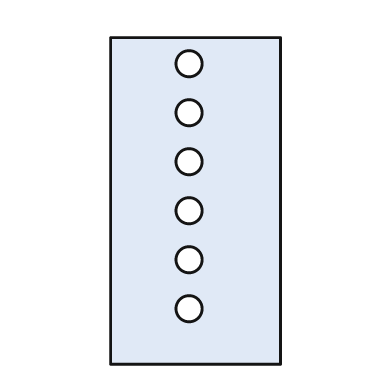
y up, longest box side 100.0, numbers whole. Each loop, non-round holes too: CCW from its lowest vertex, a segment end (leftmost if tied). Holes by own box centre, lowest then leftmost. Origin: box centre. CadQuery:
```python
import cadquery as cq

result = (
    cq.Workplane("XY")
    .moveTo(-26.0, -50.0)
    .lineTo(26.0, -50.0)
    .lineTo(26.0, 50.0)
    .lineTo(-26.0, 50.0)
    .close()
    .moveTo(-2.0, -33.0)
    .circle(4.0)
    .moveTo(-2.0, -18.0)
    .circle(4.0)
    .moveTo(-2.0, -3.0)
    .circle(4.0)
    .moveTo(-2.0, 12.0)
    .circle(4.0)
    .moveTo(-2.0, 27.0)
    .circle(4.0)
    .moveTo(-2.0, 42.0)
    .circle(4.0)
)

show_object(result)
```